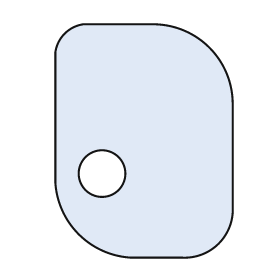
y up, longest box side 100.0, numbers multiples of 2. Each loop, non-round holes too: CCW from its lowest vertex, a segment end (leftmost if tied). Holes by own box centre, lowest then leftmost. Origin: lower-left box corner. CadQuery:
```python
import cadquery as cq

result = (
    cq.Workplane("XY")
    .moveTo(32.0, 0.0)
    .lineTo(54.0, 0.0)
    .threePointArc((70.0, 6.0), (76.0, 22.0))
    .lineTo(76.0, 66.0)
    .threePointArc((66.0, 90.0), (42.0, 100.0))
    .lineTo(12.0, 100.0)
    .threePointArc((4.0, 96.0), (0.0, 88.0))
    .lineTo(0.0, 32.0)
    .threePointArc((10.0, 10.0), (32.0, 0.0))
    .close()
    .moveTo(20.0, 36.0)
    .circle(10.0)
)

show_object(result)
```